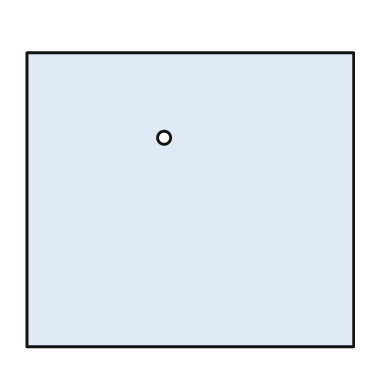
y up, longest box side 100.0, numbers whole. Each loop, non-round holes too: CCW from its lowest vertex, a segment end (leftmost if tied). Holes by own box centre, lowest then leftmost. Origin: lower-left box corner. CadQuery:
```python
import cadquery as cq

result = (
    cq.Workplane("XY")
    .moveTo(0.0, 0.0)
    .lineTo(100.0, 0.0)
    .lineTo(100.0, 90.0)
    .lineTo(0.0, 90.0)
    .close()
    .moveTo(42.0, 64.0)
    .circle(2.0)
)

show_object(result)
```